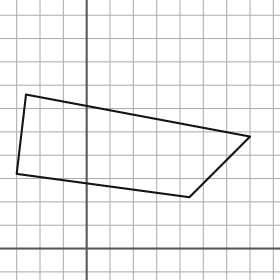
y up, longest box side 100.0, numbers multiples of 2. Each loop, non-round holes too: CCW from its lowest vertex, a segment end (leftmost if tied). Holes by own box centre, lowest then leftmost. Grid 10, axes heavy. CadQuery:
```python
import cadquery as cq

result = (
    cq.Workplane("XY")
    .moveTo(44.0, 22.0)
    .lineTo(70.0, 48.0)
    .lineTo(-26.0, 66.0)
    .lineTo(-30.0, 32.0)
    .close()
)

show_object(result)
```